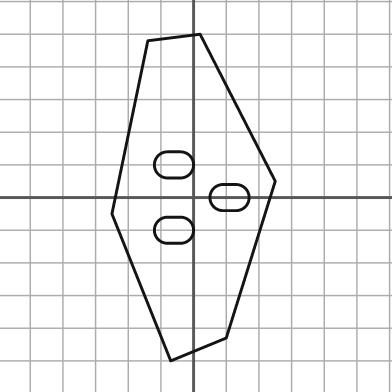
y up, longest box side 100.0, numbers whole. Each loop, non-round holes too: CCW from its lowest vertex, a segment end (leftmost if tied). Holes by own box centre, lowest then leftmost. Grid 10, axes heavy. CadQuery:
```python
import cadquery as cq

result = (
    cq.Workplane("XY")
    .moveTo(-7.0, -50.0)
    .lineTo(10.0, -43.0)
    .lineTo(25.0, 5.0)
    .lineTo(2.0, 50.0)
    .lineTo(-14.0, 48.0)
    .lineTo(-25.0, -5.0)
    .close()
    .moveTo(-8.0, -14.0)
    .lineTo(-4.0, -14.0)
    .threePointArc((0.0, -10.0), (-4.0, -6.0))
    .lineTo(-8.0, -6.0)
    .threePointArc((-12.0, -10.0), (-8.0, -14.0))
    .close()
    .moveTo(9.0, -4.0)
    .lineTo(13.0, -4.0)
    .threePointArc((17.0, 0.0), (13.0, 4.0))
    .lineTo(9.0, 4.0)
    .threePointArc((5.0, 0.0), (9.0, -4.0))
    .close()
    .moveTo(-8.0, 6.0)
    .lineTo(-4.0, 6.0)
    .threePointArc((0.0, 10.0), (-4.0, 14.0))
    .lineTo(-8.0, 14.0)
    .threePointArc((-12.0, 10.0), (-8.0, 6.0))
    .close()
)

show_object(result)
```